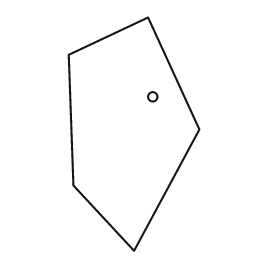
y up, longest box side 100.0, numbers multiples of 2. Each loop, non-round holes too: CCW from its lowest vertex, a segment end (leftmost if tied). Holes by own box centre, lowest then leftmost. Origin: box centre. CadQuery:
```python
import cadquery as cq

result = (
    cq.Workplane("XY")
    .moveTo(0.0, -50.0)
    .lineTo(28.0, 2.0)
    .lineTo(6.0, 50.0)
    .lineTo(-28.0, 34.0)
    .lineTo(-26.0, -22.0)
    .close()
    .moveTo(8.0, 16.0)
    .circle(2.0)
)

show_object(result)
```